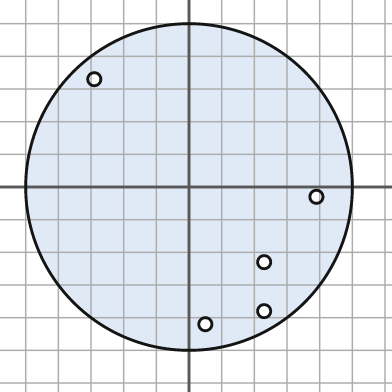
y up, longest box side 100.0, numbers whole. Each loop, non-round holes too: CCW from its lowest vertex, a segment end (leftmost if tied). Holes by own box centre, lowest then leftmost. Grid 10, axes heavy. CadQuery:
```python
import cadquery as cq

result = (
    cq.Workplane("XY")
    .moveTo(0.0, 0.0)
    .circle(50.0)
    .moveTo(5.0, -42.0)
    .circle(2.0)
    .moveTo(23.0, -38.0)
    .circle(2.0)
    .moveTo(23.0, -23.0)
    .circle(2.0)
    .moveTo(39.0, -3.0)
    .circle(2.0)
    .moveTo(-29.0, 33.0)
    .circle(2.0)
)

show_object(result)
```